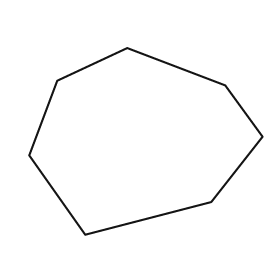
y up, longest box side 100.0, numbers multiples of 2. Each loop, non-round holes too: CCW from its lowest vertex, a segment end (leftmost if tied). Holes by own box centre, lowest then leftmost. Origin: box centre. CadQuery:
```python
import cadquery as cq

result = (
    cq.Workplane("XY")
    .moveTo(-26.0, -40.0)
    .lineTo(28.0, -26.0)
    .lineTo(50.0, 2.0)
    .lineTo(34.0, 24.0)
    .lineTo(-8.0, 40.0)
    .lineTo(-38.0, 26.0)
    .lineTo(-50.0, -6.0)
    .close()
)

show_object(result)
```